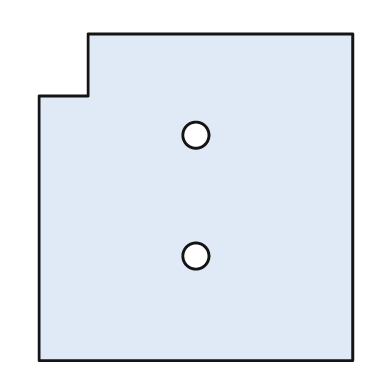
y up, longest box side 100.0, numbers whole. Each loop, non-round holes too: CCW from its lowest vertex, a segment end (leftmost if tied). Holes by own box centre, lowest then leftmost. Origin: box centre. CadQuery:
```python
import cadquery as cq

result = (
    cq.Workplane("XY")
    .moveTo(-48.0, -50.0)
    .lineTo(48.0, -50.0)
    .lineTo(48.0, 50.0)
    .lineTo(-33.0, 50.0)
    .lineTo(-33.0, 31.0)
    .lineTo(-48.0, 31.0)
    .close()
    .moveTo(0.0, -18.0)
    .circle(4.0)
    .moveTo(0.0, 19.0)
    .circle(4.0)
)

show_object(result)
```